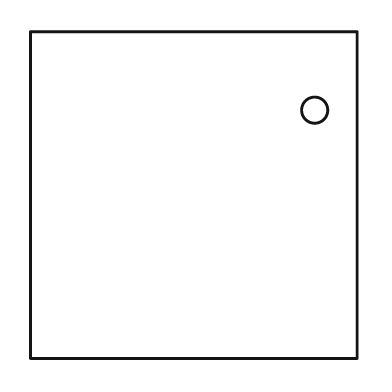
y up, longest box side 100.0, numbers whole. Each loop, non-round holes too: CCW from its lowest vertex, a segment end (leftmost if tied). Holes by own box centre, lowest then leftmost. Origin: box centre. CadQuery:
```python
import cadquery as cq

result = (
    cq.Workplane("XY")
    .moveTo(-50.0, -50.0)
    .lineTo(50.0, -50.0)
    .lineTo(50.0, 50.0)
    .lineTo(-50.0, 50.0)
    .close()
    .moveTo(37.0, 26.0)
    .circle(4.0)
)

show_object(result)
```